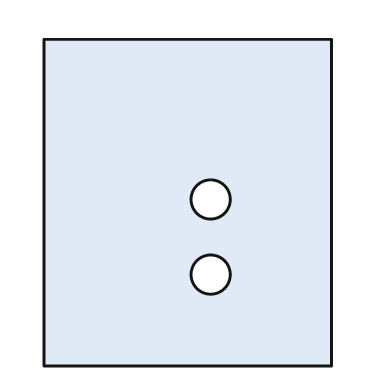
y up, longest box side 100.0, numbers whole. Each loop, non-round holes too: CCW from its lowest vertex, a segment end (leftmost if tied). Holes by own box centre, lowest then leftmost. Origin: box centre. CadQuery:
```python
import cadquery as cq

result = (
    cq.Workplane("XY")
    .moveTo(-44.0, -50.0)
    .lineTo(44.0, -50.0)
    .lineTo(44.0, 50.0)
    .lineTo(-44.0, 50.0)
    .close()
    .moveTo(7.0, -22.0)
    .circle(6.0)
    .moveTo(7.0, 1.0)
    .circle(6.0)
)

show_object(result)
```